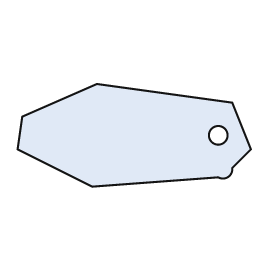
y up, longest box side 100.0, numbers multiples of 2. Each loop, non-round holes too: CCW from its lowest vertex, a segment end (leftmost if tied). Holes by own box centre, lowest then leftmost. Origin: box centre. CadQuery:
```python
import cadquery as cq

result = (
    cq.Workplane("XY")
    .moveTo(-18.0, -22.0)
    .lineTo(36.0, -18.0)
    .threePointArc((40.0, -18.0), (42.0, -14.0))
    .lineTo(50.0, -6.0)
    .lineTo(42.0, 14.0)
    .lineTo(-16.0, 22.0)
    .lineTo(-48.0, 8.0)
    .lineTo(-50.0, -6.0)
    .close()
    .moveTo(36.0, 0.0)
    .circle(4.0)
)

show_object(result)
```